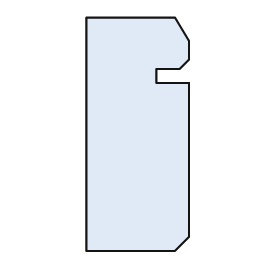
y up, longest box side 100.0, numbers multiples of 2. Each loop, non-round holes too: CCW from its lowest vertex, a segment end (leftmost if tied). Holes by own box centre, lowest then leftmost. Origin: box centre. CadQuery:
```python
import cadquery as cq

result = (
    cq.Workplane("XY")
    .moveTo(-22.0, -50.0)
    .lineTo(16.0, -50.0)
    .lineTo(22.0, -44.0)
    .lineTo(22.0, 22.0)
    .lineTo(8.0, 22.0)
    .lineTo(8.0, 28.0)
    .lineTo(18.0, 28.0)
    .lineTo(22.0, 32.0)
    .lineTo(22.0, 40.0)
    .lineTo(16.0, 50.0)
    .lineTo(-22.0, 50.0)
    .close()
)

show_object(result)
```